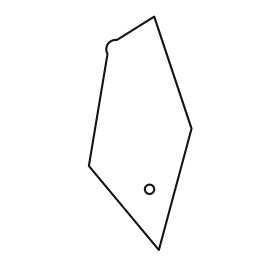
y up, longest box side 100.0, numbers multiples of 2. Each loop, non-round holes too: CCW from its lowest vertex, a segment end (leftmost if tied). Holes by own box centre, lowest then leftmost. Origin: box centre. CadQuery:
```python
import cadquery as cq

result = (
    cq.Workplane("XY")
    .moveTo(8.0, -50.0)
    .lineTo(22.0, 2.0)
    .lineTo(6.0, 50.0)
    .lineTo(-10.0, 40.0)
    .threePointArc((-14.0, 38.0), (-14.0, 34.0))
    .lineTo(-22.0, -14.0)
    .close()
    .moveTo(4.0, -24.0)
    .circle(2.0)
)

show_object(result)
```